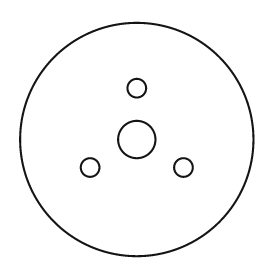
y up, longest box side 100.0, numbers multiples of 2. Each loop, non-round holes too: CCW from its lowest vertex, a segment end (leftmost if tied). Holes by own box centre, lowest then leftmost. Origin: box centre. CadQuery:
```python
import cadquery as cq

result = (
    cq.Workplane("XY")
    .moveTo(0.0, 0.0)
    .circle(50.0)
    .moveTo(-20.0, -12.0)
    .circle(4.0)
    .moveTo(20.0, -12.0)
    .circle(4.0)
    .moveTo(0.0, 0.0)
    .circle(8.0)
    .moveTo(0.0, 22.0)
    .circle(4.0)
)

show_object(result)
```